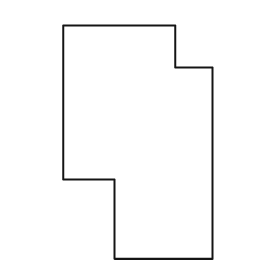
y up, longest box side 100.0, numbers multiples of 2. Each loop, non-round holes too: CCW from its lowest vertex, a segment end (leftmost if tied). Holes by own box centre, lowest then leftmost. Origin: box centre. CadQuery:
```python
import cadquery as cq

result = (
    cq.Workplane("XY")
    .moveTo(-10.0, -50.0)
    .lineTo(32.0, -50.0)
    .lineTo(32.0, 32.0)
    .lineTo(16.0, 32.0)
    .lineTo(16.0, 50.0)
    .lineTo(-32.0, 50.0)
    .lineTo(-32.0, -16.0)
    .lineTo(-10.0, -16.0)
    .close()
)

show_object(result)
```